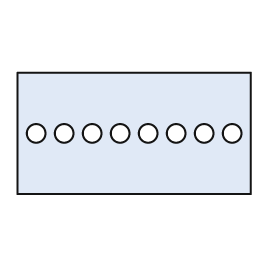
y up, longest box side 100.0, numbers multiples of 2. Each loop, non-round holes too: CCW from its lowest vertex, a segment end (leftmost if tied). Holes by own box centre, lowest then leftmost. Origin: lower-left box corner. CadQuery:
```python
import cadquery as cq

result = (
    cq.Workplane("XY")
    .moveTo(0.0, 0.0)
    .lineTo(100.0, 0.0)
    .lineTo(100.0, 52.0)
    .lineTo(0.0, 52.0)
    .close()
    .moveTo(8.0, 26.0)
    .circle(4.0)
    .moveTo(20.0, 26.0)
    .circle(4.0)
    .moveTo(32.0, 26.0)
    .circle(4.0)
    .moveTo(44.0, 26.0)
    .circle(4.0)
    .moveTo(56.0, 26.0)
    .circle(4.0)
    .moveTo(68.0, 26.0)
    .circle(4.0)
    .moveTo(80.0, 26.0)
    .circle(4.0)
    .moveTo(92.0, 26.0)
    .circle(4.0)
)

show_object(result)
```